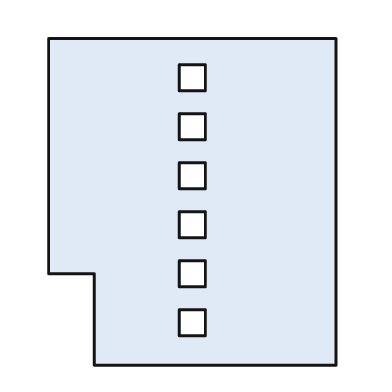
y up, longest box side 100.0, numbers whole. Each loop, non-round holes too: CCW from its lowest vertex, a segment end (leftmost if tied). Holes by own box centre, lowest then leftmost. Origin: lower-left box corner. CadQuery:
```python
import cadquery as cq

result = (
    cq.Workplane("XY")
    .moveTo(14.0, 0.0)
    .lineTo(88.0, 0.0)
    .lineTo(88.0, 100.0)
    .lineTo(0.0, 100.0)
    .lineTo(0.0, 28.0)
    .lineTo(14.0, 28.0)
    .close()
    .moveTo(40.0, 9.0)
    .lineTo(48.0, 9.0)
    .lineTo(48.0, 17.0)
    .lineTo(40.0, 17.0)
    .close()
    .moveTo(40.0, 24.0)
    .lineTo(48.0, 24.0)
    .lineTo(48.0, 32.0)
    .lineTo(40.0, 32.0)
    .close()
    .moveTo(40.0, 39.0)
    .lineTo(48.0, 39.0)
    .lineTo(48.0, 47.0)
    .lineTo(40.0, 47.0)
    .close()
    .moveTo(40.0, 54.0)
    .lineTo(48.0, 54.0)
    .lineTo(48.0, 62.0)
    .lineTo(40.0, 62.0)
    .close()
    .moveTo(40.0, 69.0)
    .lineTo(48.0, 69.0)
    .lineTo(48.0, 77.0)
    .lineTo(40.0, 77.0)
    .close()
    .moveTo(40.0, 84.0)
    .lineTo(48.0, 84.0)
    .lineTo(48.0, 92.0)
    .lineTo(40.0, 92.0)
    .close()
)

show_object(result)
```